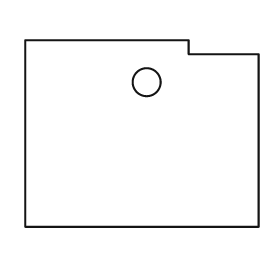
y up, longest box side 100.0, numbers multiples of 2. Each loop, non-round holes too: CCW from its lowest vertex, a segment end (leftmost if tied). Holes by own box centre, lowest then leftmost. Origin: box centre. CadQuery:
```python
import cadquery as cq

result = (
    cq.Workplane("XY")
    .moveTo(-50.0, -40.0)
    .lineTo(50.0, -40.0)
    .lineTo(50.0, 34.0)
    .lineTo(20.0, 34.0)
    .lineTo(20.0, 40.0)
    .lineTo(-50.0, 40.0)
    .close()
    .moveTo(2.0, 22.0)
    .circle(6.0)
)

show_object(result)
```